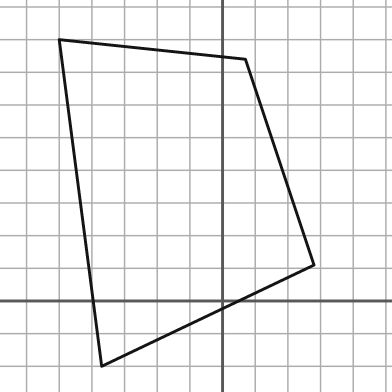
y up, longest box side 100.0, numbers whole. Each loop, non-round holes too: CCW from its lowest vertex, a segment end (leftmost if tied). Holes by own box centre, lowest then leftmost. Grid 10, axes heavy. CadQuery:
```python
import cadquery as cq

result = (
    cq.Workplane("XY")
    .moveTo(-37.0, -20.0)
    .lineTo(28.0, 11.0)
    .lineTo(7.0, 74.0)
    .lineTo(-50.0, 80.0)
    .close()
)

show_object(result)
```